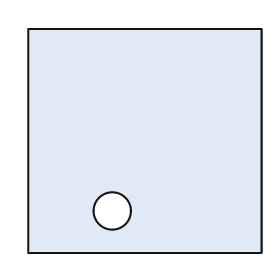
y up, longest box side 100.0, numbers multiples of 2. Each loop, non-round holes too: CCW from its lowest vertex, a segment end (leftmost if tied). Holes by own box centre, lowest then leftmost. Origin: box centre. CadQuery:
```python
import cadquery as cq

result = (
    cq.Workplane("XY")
    .moveTo(-50.0, -48.0)
    .lineTo(50.0, -48.0)
    .lineTo(50.0, 48.0)
    .lineTo(-50.0, 48.0)
    .close()
    .moveTo(-14.0, -30.0)
    .circle(8.0)
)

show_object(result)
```